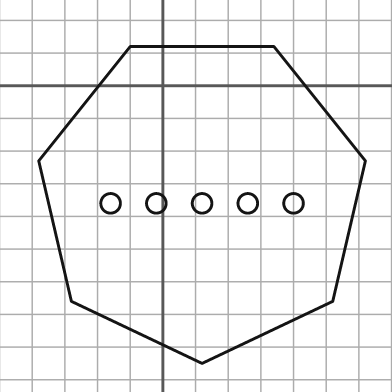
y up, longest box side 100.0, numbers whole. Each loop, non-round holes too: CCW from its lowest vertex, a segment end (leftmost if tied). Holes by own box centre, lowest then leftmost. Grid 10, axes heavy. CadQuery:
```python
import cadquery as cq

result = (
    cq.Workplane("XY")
    .moveTo(12.0, -85.0)
    .lineTo(52.0, -66.0)
    .lineTo(62.0, -23.0)
    .lineTo(34.0, 12.0)
    .lineTo(-10.0, 12.0)
    .lineTo(-38.0, -23.0)
    .lineTo(-28.0, -66.0)
    .close()
    .moveTo(-16.0, -36.0)
    .circle(3.0)
    .moveTo(-2.0, -36.0)
    .circle(3.0)
    .moveTo(12.0, -36.0)
    .circle(3.0)
    .moveTo(26.0, -36.0)
    .circle(3.0)
    .moveTo(40.0, -36.0)
    .circle(3.0)
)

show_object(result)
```